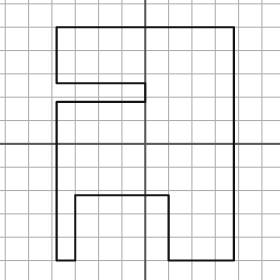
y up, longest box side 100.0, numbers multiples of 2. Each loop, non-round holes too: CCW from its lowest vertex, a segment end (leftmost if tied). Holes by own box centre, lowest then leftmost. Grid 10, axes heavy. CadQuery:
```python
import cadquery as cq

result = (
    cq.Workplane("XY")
    .moveTo(-38.0, -50.0)
    .lineTo(-30.0, -50.0)
    .lineTo(-30.0, -22.0)
    .lineTo(10.0, -22.0)
    .lineTo(10.0, -50.0)
    .lineTo(38.0, -50.0)
    .lineTo(38.0, 50.0)
    .lineTo(-38.0, 50.0)
    .lineTo(-38.0, 26.0)
    .lineTo(0.0, 26.0)
    .lineTo(0.0, 18.0)
    .lineTo(-38.0, 18.0)
    .close()
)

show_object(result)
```